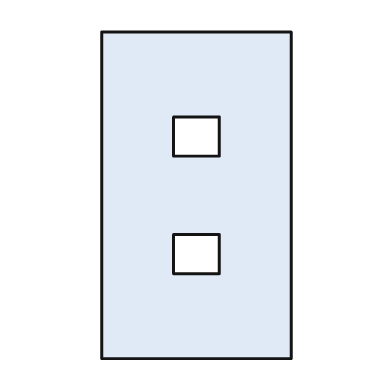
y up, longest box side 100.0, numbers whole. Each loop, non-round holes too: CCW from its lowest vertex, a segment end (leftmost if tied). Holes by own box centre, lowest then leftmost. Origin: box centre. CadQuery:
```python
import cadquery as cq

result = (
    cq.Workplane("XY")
    .moveTo(-29.0, -50.0)
    .lineTo(29.0, -50.0)
    .lineTo(29.0, 50.0)
    .lineTo(-29.0, 50.0)
    .close()
    .moveTo(-7.0, -24.0)
    .lineTo(7.0, -24.0)
    .lineTo(7.0, -12.0)
    .lineTo(-7.0, -12.0)
    .close()
    .moveTo(-7.0, 12.0)
    .lineTo(7.0, 12.0)
    .lineTo(7.0, 24.0)
    .lineTo(-7.0, 24.0)
    .close()
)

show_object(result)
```